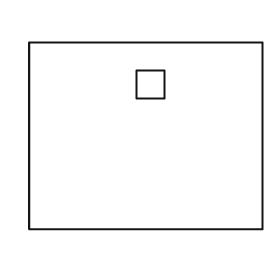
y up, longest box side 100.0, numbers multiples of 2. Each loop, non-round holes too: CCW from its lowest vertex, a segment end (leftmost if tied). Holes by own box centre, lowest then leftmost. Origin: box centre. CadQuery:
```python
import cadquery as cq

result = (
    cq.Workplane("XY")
    .moveTo(-50.0, -40.0)
    .lineTo(50.0, -40.0)
    .lineTo(50.0, 40.0)
    .lineTo(-50.0, 40.0)
    .close()
    .moveTo(-4.0, 16.0)
    .lineTo(8.0, 16.0)
    .lineTo(8.0, 28.0)
    .lineTo(-4.0, 28.0)
    .close()
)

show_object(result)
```